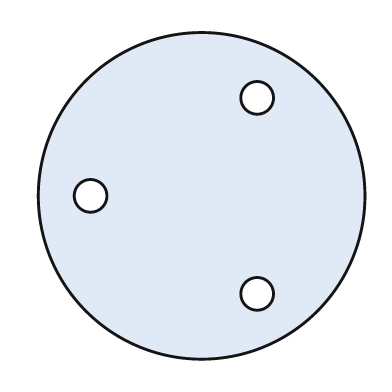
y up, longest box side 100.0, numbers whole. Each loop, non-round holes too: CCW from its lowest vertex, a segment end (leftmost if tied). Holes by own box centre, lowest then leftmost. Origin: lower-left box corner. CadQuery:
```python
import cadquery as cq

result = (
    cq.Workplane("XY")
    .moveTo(50.0, 50.0)
    .circle(50.0)
    .moveTo(67.0, 20.0)
    .circle(5.0)
    .moveTo(16.0, 50.0)
    .circle(5.0)
    .moveTo(67.0, 80.0)
    .circle(5.0)
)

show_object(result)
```